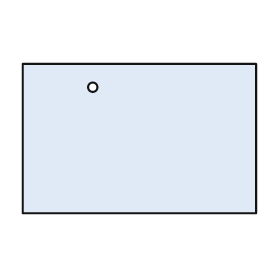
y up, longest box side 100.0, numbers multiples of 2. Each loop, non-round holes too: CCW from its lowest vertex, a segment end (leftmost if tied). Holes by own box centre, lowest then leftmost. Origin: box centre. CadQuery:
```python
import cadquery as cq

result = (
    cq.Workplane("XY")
    .moveTo(-50.0, -32.0)
    .lineTo(50.0, -32.0)
    .lineTo(50.0, 32.0)
    .lineTo(-50.0, 32.0)
    .close()
    .moveTo(-20.0, 22.0)
    .circle(2.0)
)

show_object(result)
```